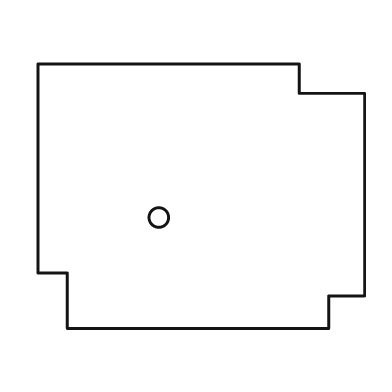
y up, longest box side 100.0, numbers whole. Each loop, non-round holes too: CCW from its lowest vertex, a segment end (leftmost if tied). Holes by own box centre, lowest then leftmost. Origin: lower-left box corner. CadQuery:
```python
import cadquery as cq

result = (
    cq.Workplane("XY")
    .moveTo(9.0, 0.0)
    .lineTo(89.0, 0.0)
    .lineTo(89.0, 10.0)
    .lineTo(100.0, 10.0)
    .lineTo(100.0, 72.0)
    .lineTo(80.0, 72.0)
    .lineTo(80.0, 81.0)
    .lineTo(0.0, 81.0)
    .lineTo(0.0, 17.0)
    .lineTo(9.0, 17.0)
    .close()
    .moveTo(37.0, 34.0)
    .circle(3.0)
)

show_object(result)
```